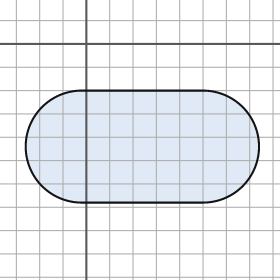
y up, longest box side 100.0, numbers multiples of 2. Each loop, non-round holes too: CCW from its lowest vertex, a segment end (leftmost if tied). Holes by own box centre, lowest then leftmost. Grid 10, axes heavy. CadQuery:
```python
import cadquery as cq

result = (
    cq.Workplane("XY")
    .moveTo(-2.0, -68.0)
    .lineTo(50.0, -68.0)
    .threePointArc((74.0, -44.0), (50.0, -20.0))
    .lineTo(-2.0, -20.0)
    .threePointArc((-26.0, -44.0), (-2.0, -68.0))
    .close()
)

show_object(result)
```